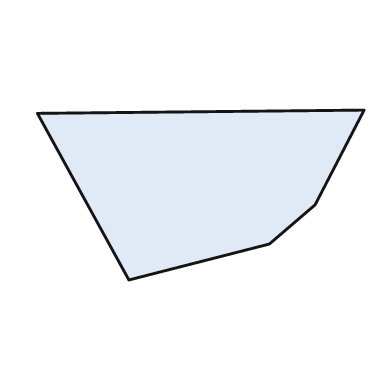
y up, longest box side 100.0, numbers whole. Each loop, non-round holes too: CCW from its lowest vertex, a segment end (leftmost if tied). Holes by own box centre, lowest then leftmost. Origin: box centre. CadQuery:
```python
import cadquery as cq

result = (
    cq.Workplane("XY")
    .moveTo(-22.0, -26.0)
    .lineTo(21.0, -15.0)
    .lineTo(35.0, -3.0)
    .lineTo(50.0, 26.0)
    .lineTo(-50.0, 25.0)
    .close()
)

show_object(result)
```